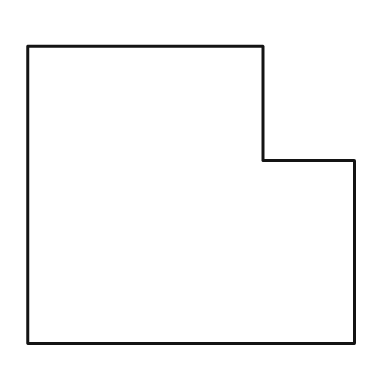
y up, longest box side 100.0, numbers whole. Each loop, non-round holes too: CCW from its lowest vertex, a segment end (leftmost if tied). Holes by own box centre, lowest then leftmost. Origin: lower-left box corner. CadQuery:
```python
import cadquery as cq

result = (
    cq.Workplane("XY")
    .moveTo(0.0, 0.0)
    .lineTo(100.0, 0.0)
    .lineTo(100.0, 56.0)
    .lineTo(72.0, 56.0)
    .lineTo(72.0, 91.0)
    .lineTo(0.0, 91.0)
    .close()
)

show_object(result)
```